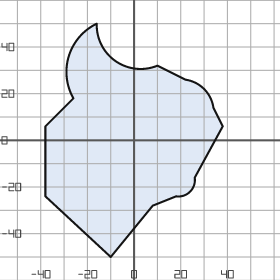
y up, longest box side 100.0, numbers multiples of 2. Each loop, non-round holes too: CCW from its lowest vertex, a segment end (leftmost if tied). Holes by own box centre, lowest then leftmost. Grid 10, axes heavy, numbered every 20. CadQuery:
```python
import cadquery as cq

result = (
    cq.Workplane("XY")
    .moveTo(-10.0, -50.0)
    .lineTo(8.0, -28.0)
    .lineTo(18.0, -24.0)
    .threePointArc((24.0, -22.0), (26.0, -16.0))
    .lineTo(38.0, 6.0)
    .lineTo(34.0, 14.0)
    .threePointArc((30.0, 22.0), (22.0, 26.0))
    .lineTo(10.0, 32.0)
    .threePointArc((-8.0, 34.0), (-16.0, 50.0))
    .threePointArc((-28.0, 36.0), (-26.0, 18.0))
    .lineTo(-38.0, 6.0)
    .lineTo(-38.0, -24.0)
    .close()
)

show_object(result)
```